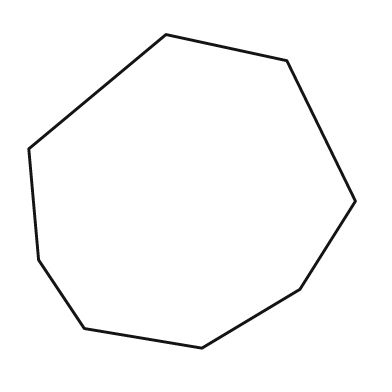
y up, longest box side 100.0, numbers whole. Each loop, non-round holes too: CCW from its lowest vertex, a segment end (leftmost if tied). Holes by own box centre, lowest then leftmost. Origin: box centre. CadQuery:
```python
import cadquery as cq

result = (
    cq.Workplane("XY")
    .moveTo(3.0, -48.0)
    .lineTo(33.0, -30.0)
    .lineTo(50.0, -3.0)
    .lineTo(29.0, 40.0)
    .lineTo(-8.0, 48.0)
    .lineTo(-50.0, 13.0)
    .lineTo(-47.0, -21.0)
    .lineTo(-33.0, -42.0)
    .close()
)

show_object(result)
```